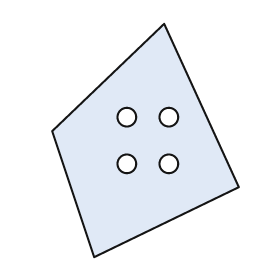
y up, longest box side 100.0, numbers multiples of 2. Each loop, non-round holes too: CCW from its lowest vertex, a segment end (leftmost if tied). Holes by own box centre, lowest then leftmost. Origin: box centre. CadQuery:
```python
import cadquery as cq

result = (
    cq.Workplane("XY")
    .moveTo(-22.0, -50.0)
    .lineTo(40.0, -20.0)
    .lineTo(8.0, 50.0)
    .lineTo(-40.0, 4.0)
    .close()
    .moveTo(-8.0, -10.0)
    .circle(4.0)
    .moveTo(10.0, -10.0)
    .circle(4.0)
    .moveTo(-8.0, 10.0)
    .circle(4.0)
    .moveTo(10.0, 10.0)
    .circle(4.0)
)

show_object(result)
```